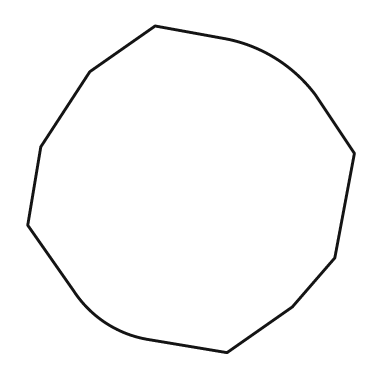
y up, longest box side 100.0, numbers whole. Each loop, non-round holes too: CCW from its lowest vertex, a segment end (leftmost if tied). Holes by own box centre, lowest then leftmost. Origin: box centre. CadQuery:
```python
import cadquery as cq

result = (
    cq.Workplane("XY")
    .moveTo(11.0, -50.0)
    .lineTo(31.0, -36.0)
    .lineTo(44.0, -21.0)
    .lineTo(50.0, 11.0)
    .lineTo(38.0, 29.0)
    .threePointArc((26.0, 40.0), (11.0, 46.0))
    .lineTo(-11.0, 50.0)
    .lineTo(-31.0, 36.0)
    .lineTo(-46.0, 13.0)
    .lineTo(-50.0, -11.0)
    .lineTo(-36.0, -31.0)
    .threePointArc((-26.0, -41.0), (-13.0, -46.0))
    .close()
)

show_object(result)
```